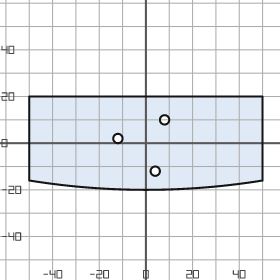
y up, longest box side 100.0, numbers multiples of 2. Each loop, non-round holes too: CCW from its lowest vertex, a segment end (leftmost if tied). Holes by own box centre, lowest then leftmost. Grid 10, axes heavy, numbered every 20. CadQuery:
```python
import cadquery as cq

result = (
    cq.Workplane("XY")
    .moveTo(-50.0, -16.0)
    .threePointArc((0.0, -20.0), (50.0, -16.0))
    .lineTo(50.0, 20.0)
    .lineTo(-50.0, 20.0)
    .close()
    .moveTo(4.0, -12.0)
    .circle(2.0)
    .moveTo(-12.0, 2.0)
    .circle(2.0)
    .moveTo(8.0, 10.0)
    .circle(2.0)
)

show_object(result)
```